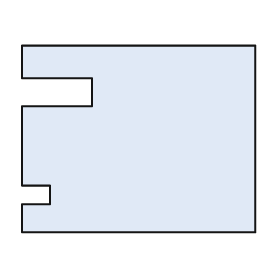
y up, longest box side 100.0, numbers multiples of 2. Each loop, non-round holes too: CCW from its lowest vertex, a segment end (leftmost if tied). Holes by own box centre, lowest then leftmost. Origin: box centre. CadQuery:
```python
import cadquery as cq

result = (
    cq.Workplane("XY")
    .moveTo(-50.0, -40.0)
    .lineTo(50.0, -40.0)
    .lineTo(50.0, 40.0)
    .lineTo(-50.0, 40.0)
    .lineTo(-50.0, 26.0)
    .lineTo(-20.0, 26.0)
    .lineTo(-20.0, 14.0)
    .lineTo(-50.0, 14.0)
    .lineTo(-50.0, -20.0)
    .lineTo(-38.0, -20.0)
    .lineTo(-38.0, -28.0)
    .lineTo(-50.0, -28.0)
    .close()
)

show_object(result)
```